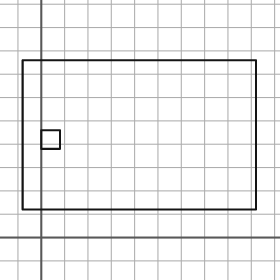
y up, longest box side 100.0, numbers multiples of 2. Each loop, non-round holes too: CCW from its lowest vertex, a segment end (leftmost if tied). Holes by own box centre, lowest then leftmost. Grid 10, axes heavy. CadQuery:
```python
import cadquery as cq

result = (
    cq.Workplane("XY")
    .moveTo(-8.0, 12.0)
    .lineTo(92.0, 12.0)
    .lineTo(92.0, 76.0)
    .lineTo(-8.0, 76.0)
    .close()
    .moveTo(0.0, 38.0)
    .lineTo(8.0, 38.0)
    .lineTo(8.0, 46.0)
    .lineTo(0.0, 46.0)
    .close()
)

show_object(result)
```